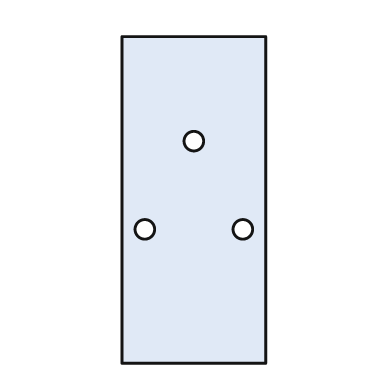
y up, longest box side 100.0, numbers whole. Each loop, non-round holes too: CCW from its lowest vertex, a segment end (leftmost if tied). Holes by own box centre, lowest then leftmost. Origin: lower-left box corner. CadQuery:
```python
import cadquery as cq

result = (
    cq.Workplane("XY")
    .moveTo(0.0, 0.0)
    .lineTo(44.0, 0.0)
    .lineTo(44.0, 100.0)
    .lineTo(0.0, 100.0)
    .close()
    .moveTo(7.0, 41.0)
    .circle(3.0)
    .moveTo(37.0, 41.0)
    .circle(3.0)
    .moveTo(22.0, 68.0)
    .circle(3.0)
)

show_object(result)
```